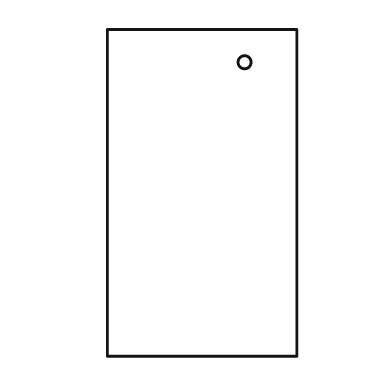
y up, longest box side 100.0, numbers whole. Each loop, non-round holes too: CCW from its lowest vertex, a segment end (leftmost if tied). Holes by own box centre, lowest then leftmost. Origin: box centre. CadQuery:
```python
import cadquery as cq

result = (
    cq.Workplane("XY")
    .moveTo(-29.0, -50.0)
    .lineTo(29.0, -50.0)
    .lineTo(29.0, 50.0)
    .lineTo(-29.0, 50.0)
    .close()
    .moveTo(13.0, 40.0)
    .circle(2.0)
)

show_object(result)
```